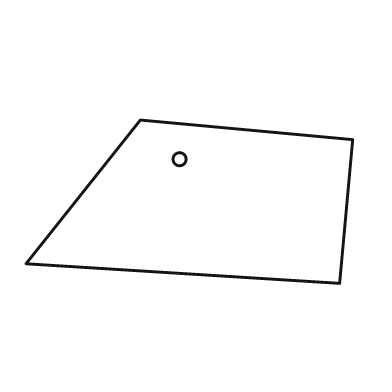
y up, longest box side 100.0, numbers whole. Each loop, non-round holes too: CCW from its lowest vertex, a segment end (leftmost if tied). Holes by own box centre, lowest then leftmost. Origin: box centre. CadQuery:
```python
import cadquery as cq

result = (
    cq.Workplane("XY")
    .moveTo(46.0, -25.0)
    .lineTo(50.0, 19.0)
    .lineTo(-15.0, 25.0)
    .lineTo(-50.0, -19.0)
    .close()
    .moveTo(-3.0, 13.0)
    .circle(2.0)
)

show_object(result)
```